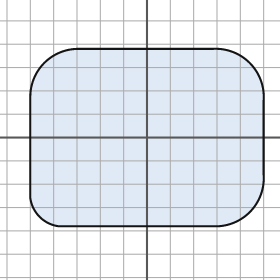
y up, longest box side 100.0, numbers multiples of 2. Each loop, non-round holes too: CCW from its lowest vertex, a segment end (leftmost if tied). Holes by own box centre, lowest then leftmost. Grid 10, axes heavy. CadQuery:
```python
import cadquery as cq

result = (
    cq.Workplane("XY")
    .moveTo(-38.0, -38.0)
    .lineTo(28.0, -38.0)
    .threePointArc((44.0, -32.0), (50.0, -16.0))
    .lineTo(50.0, 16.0)
    .threePointArc((44.0, 32.0), (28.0, 38.0))
    .lineTo(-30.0, 38.0)
    .threePointArc((-44.0, 32.0), (-50.0, 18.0))
    .lineTo(-50.0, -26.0)
    .threePointArc((-46.0, -34.0), (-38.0, -38.0))
    .close()
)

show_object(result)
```